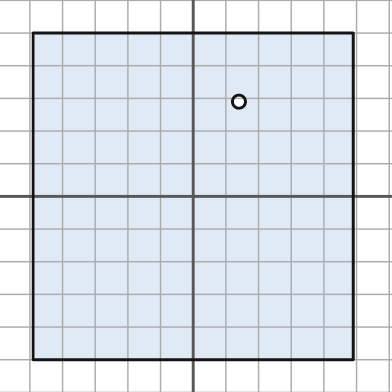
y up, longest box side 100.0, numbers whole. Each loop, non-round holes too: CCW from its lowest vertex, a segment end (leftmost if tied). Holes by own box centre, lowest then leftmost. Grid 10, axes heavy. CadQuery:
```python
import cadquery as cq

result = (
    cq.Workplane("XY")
    .moveTo(-49.0, -50.0)
    .lineTo(49.0, -50.0)
    .lineTo(49.0, 50.0)
    .lineTo(-49.0, 50.0)
    .close()
    .moveTo(14.0, 29.0)
    .circle(2.0)
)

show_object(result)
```